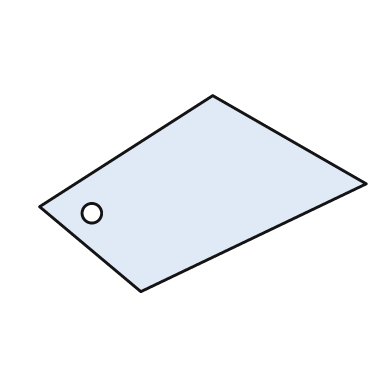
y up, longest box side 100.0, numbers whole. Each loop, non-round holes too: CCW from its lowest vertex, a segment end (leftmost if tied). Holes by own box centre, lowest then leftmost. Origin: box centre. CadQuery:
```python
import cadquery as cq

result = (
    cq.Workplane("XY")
    .moveTo(-19.0, -30.0)
    .lineTo(50.0, 3.0)
    .lineTo(3.0, 30.0)
    .lineTo(-50.0, -4.0)
    .close()
    .moveTo(-34.0, -6.0)
    .circle(3.0)
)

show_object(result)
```